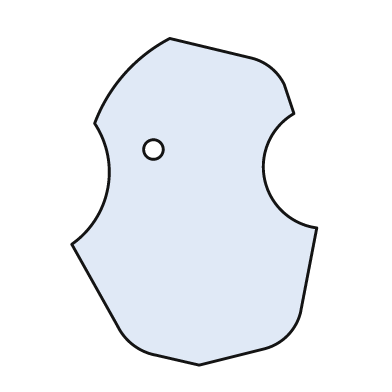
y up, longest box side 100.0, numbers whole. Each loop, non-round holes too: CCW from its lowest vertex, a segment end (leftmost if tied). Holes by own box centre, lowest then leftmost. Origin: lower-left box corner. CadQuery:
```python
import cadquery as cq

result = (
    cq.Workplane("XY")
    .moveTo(39.0, 0.0)
    .lineTo(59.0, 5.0)
    .threePointArc((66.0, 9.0), (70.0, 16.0))
    .lineTo(75.0, 42.0)
    .threePointArc((59.0, 57.0), (68.0, 77.0))
    .lineTo(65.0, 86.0)
    .threePointArc((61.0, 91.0), (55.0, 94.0))
    .lineTo(30.0, 100.0)
    .threePointArc((16.0, 89.0), (7.0, 74.0))
    .threePointArc((11.0, 54.0), (0.0, 37.0))
    .lineTo(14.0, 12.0)
    .threePointArc((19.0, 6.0), (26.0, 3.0))
    .close()
    .moveTo(25.0, 66.0)
    .circle(3.0)
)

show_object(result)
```